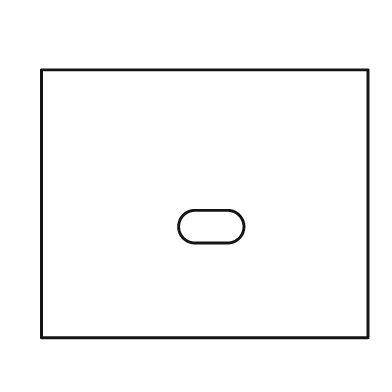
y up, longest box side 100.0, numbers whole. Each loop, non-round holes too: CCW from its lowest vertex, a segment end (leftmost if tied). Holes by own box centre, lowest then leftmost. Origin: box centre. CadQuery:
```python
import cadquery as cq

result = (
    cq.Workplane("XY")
    .moveTo(-50.0, -41.0)
    .lineTo(50.0, -41.0)
    .lineTo(50.0, 41.0)
    .lineTo(-50.0, 41.0)
    .close()
    .moveTo(-3.0, -12.0)
    .lineTo(7.0, -12.0)
    .threePointArc((12.0, -7.0), (7.0, -2.0))
    .lineTo(-3.0, -2.0)
    .threePointArc((-8.0, -7.0), (-3.0, -12.0))
    .close()
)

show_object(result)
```